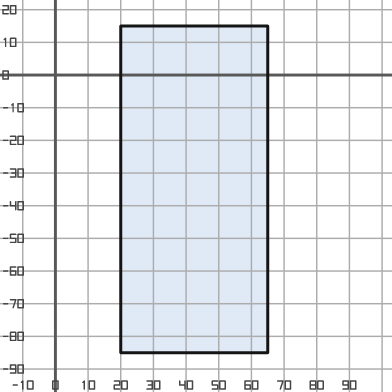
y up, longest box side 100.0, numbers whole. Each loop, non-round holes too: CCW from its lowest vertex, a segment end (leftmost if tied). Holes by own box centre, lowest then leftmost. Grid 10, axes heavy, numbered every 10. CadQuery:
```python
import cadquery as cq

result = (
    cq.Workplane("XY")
    .moveTo(20.0, -85.0)
    .lineTo(65.0, -85.0)
    .lineTo(65.0, 15.0)
    .lineTo(20.0, 15.0)
    .close()
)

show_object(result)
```